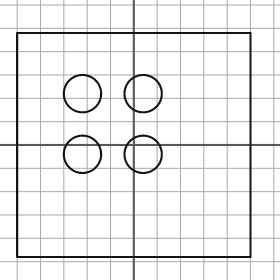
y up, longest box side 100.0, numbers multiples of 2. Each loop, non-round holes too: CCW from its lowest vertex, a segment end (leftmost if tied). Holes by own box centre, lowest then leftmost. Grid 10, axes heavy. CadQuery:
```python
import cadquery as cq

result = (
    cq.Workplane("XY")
    .moveTo(-50.0, -48.0)
    .lineTo(50.0, -48.0)
    .lineTo(50.0, 48.0)
    .lineTo(-50.0, 48.0)
    .close()
    .moveTo(-22.0, -4.0)
    .circle(8.0)
    .moveTo(4.0, -4.0)
    .circle(8.0)
    .moveTo(-22.0, 22.0)
    .circle(8.0)
    .moveTo(4.0, 22.0)
    .circle(8.0)
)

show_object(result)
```